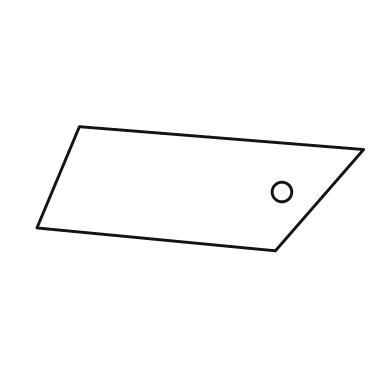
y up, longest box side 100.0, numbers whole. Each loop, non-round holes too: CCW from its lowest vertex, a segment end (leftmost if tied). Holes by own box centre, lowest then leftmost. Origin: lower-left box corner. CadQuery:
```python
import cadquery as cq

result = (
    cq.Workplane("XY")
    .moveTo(73.0, 0.0)
    .lineTo(100.0, 31.0)
    .lineTo(13.0, 38.0)
    .lineTo(0.0, 7.0)
    .close()
    .moveTo(75.0, 18.0)
    .circle(3.0)
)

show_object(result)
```